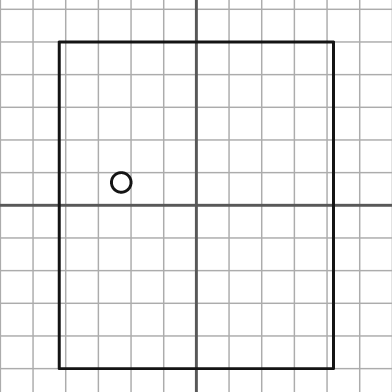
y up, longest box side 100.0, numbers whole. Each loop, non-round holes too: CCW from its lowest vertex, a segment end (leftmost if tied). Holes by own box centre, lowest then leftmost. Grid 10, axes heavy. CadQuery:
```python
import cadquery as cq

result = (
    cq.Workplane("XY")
    .moveTo(-42.0, -50.0)
    .lineTo(42.0, -50.0)
    .lineTo(42.0, 50.0)
    .lineTo(-42.0, 50.0)
    .close()
    .moveTo(-23.0, 7.0)
    .circle(3.0)
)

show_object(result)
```